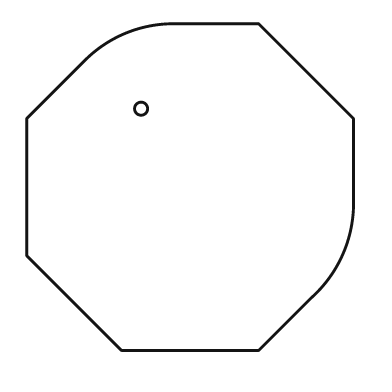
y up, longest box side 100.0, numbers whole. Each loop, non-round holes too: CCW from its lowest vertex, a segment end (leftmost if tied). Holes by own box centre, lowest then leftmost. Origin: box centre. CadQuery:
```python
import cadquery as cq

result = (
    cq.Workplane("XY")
    .moveTo(-21.0, -50.0)
    .lineTo(21.0, -50.0)
    .lineTo(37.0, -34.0)
    .threePointArc((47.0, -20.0), (50.0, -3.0))
    .lineTo(50.0, 21.0)
    .lineTo(21.0, 50.0)
    .lineTo(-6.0, 50.0)
    .threePointArc((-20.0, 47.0), (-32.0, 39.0))
    .lineTo(-50.0, 21.0)
    .lineTo(-50.0, -21.0)
    .close()
    .moveTo(-15.0, 24.0)
    .circle(2.0)
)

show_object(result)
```